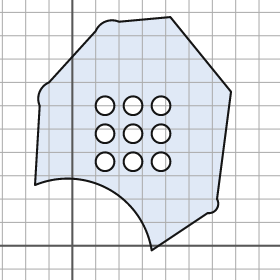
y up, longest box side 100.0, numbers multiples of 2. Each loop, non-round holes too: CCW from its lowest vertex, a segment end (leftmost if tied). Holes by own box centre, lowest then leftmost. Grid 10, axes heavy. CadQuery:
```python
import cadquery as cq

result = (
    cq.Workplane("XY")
    .moveTo(34.0, -2.0)
    .lineTo(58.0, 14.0)
    .threePointArc((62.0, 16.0), (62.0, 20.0))
    .lineTo(68.0, 66.0)
    .lineTo(42.0, 98.0)
    .lineTo(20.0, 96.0)
    .threePointArc((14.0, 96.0), (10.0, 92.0))
    .lineTo(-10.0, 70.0)
    .threePointArc((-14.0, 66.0), (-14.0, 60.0))
    .lineTo(-16.0, 26.0)
    .threePointArc((16.0, 24.0), (34.0, -2.0))
    .close()
    .moveTo(14.0, 36.0)
    .circle(4.0)
    .moveTo(26.0, 36.0)
    .circle(4.0)
    .moveTo(38.0, 36.0)
    .circle(4.0)
    .moveTo(14.0, 48.0)
    .circle(4.0)
    .moveTo(26.0, 48.0)
    .circle(4.0)
    .moveTo(38.0, 48.0)
    .circle(4.0)
    .moveTo(14.0, 60.0)
    .circle(4.0)
    .moveTo(26.0, 60.0)
    .circle(4.0)
    .moveTo(38.0, 60.0)
    .circle(4.0)
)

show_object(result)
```